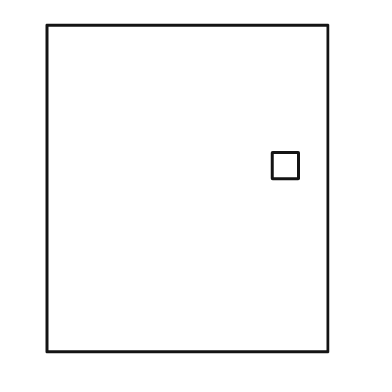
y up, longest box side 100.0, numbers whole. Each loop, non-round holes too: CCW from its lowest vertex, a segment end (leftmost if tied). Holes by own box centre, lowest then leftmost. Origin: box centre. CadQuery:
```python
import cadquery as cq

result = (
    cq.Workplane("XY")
    .moveTo(-43.0, -50.0)
    .lineTo(43.0, -50.0)
    .lineTo(43.0, 50.0)
    .lineTo(-43.0, 50.0)
    .close()
    .moveTo(26.0, 3.0)
    .lineTo(34.0, 3.0)
    .lineTo(34.0, 11.0)
    .lineTo(26.0, 11.0)
    .close()
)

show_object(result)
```